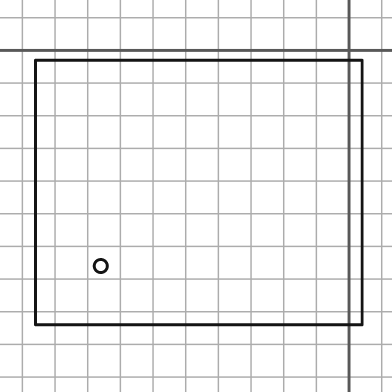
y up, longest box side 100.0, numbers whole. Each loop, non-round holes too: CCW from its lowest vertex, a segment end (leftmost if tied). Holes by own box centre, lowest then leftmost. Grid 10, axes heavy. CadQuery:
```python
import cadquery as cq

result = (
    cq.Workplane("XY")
    .moveTo(-96.0, -84.0)
    .lineTo(4.0, -84.0)
    .lineTo(4.0, -3.0)
    .lineTo(-96.0, -3.0)
    .close()
    .moveTo(-76.0, -66.0)
    .circle(2.0)
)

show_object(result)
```